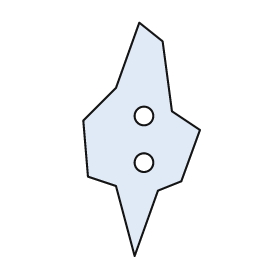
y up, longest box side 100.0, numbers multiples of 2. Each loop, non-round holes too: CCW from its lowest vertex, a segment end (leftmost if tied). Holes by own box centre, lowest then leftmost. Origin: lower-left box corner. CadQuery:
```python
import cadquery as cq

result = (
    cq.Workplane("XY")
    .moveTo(22.0, 0.0)
    .lineTo(32.0, 28.0)
    .lineTo(42.0, 32.0)
    .lineTo(50.0, 54.0)
    .lineTo(38.0, 62.0)
    .lineTo(34.0, 92.0)
    .lineTo(24.0, 100.0)
    .lineTo(14.0, 72.0)
    .lineTo(0.0, 58.0)
    .lineTo(2.0, 34.0)
    .lineTo(14.0, 30.0)
    .close()
    .moveTo(26.0, 40.0)
    .circle(4.0)
    .moveTo(26.0, 60.0)
    .circle(4.0)
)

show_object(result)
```